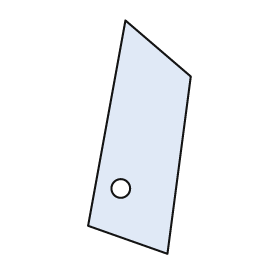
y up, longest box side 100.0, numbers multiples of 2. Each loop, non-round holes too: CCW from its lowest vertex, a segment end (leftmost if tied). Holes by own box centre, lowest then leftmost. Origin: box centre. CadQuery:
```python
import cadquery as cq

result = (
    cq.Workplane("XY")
    .moveTo(12.0, -50.0)
    .lineTo(22.0, 26.0)
    .lineTo(-6.0, 50.0)
    .lineTo(-22.0, -38.0)
    .close()
    .moveTo(-8.0, -22.0)
    .circle(4.0)
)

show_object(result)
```